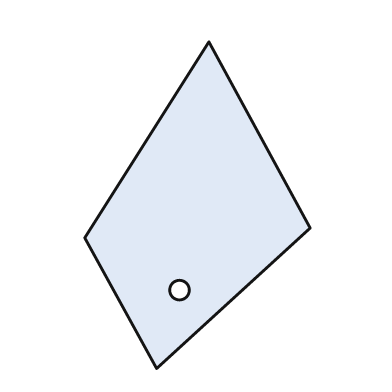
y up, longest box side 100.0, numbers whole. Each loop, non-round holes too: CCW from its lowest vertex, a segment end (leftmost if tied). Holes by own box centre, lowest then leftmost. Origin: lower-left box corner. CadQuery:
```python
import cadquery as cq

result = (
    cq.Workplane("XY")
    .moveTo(22.0, 0.0)
    .lineTo(69.0, 43.0)
    .lineTo(38.0, 100.0)
    .lineTo(0.0, 40.0)
    .close()
    .moveTo(29.0, 24.0)
    .circle(3.0)
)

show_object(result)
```